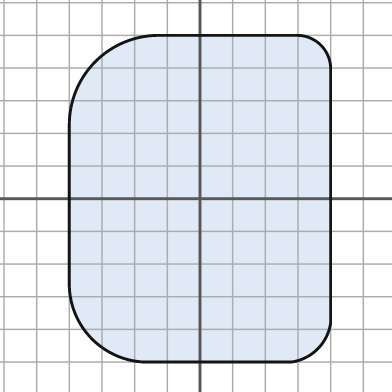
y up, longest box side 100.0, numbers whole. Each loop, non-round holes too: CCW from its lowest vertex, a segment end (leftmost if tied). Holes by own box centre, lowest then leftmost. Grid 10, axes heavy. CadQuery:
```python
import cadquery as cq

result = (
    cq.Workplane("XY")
    .moveTo(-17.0, -50.0)
    .lineTo(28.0, -50.0)
    .threePointArc((36.0, -46.0), (40.0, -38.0))
    .lineTo(40.0, 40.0)
    .threePointArc((37.0, 47.0), (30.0, 50.0))
    .lineTo(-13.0, 50.0)
    .threePointArc((-32.0, 42.0), (-40.0, 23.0))
    .lineTo(-40.0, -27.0)
    .threePointArc((-33.0, -43.0), (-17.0, -50.0))
    .close()
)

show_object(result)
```